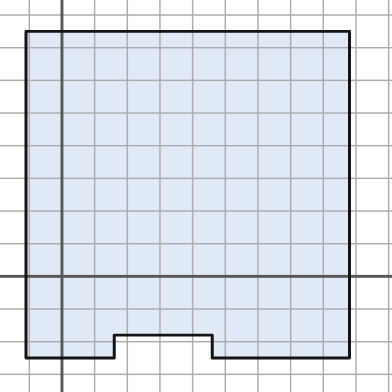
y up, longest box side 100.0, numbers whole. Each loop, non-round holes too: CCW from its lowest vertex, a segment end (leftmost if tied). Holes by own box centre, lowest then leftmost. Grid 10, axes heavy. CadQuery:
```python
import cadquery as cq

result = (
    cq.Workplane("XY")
    .moveTo(-11.0, -25.0)
    .lineTo(16.0, -25.0)
    .lineTo(16.0, -18.0)
    .lineTo(46.0, -18.0)
    .lineTo(46.0, -25.0)
    .lineTo(88.0, -25.0)
    .lineTo(88.0, 75.0)
    .lineTo(-11.0, 75.0)
    .close()
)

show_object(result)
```